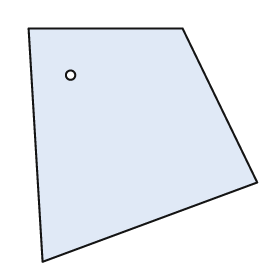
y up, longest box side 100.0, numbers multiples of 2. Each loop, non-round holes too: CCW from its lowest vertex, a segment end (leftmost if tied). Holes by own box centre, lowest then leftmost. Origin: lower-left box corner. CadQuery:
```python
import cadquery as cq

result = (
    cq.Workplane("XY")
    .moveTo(6.0, 0.0)
    .lineTo(98.0, 34.0)
    .lineTo(66.0, 100.0)
    .lineTo(0.0, 100.0)
    .close()
    .moveTo(18.0, 80.0)
    .circle(2.0)
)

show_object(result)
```